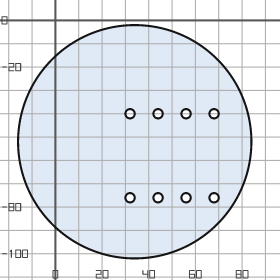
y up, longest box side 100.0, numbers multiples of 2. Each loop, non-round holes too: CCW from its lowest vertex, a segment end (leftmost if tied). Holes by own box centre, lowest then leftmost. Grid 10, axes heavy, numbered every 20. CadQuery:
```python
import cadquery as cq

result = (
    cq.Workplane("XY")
    .moveTo(34.0, -52.0)
    .circle(50.0)
    .moveTo(32.0, -76.0)
    .circle(2.0)
    .moveTo(44.0, -76.0)
    .circle(2.0)
    .moveTo(56.0, -76.0)
    .circle(2.0)
    .moveTo(68.0, -76.0)
    .circle(2.0)
    .moveTo(32.0, -40.0)
    .circle(2.0)
    .moveTo(44.0, -40.0)
    .circle(2.0)
    .moveTo(56.0, -40.0)
    .circle(2.0)
    .moveTo(68.0, -40.0)
    .circle(2.0)
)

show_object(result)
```